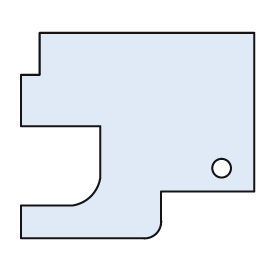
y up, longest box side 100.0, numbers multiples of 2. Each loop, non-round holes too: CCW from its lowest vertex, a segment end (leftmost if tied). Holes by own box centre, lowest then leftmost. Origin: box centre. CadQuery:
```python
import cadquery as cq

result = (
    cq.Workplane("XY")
    .moveTo(-50.0, -44.0)
    .lineTo(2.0, -44.0)
    .threePointArc((8.0, -42.0), (10.0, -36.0))
    .lineTo(10.0, -24.0)
    .lineTo(50.0, -24.0)
    .lineTo(50.0, 44.0)
    .lineTo(-42.0, 44.0)
    .lineTo(-42.0, 26.0)
    .lineTo(-50.0, 26.0)
    .lineTo(-50.0, 4.0)
    .lineTo(-16.0, 4.0)
    .lineTo(-16.0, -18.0)
    .threePointArc((-20.0, -26.0), (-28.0, -30.0))
    .lineTo(-50.0, -30.0)
    .close()
    .moveTo(36.0, -14.0)
    .circle(4.0)
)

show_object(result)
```